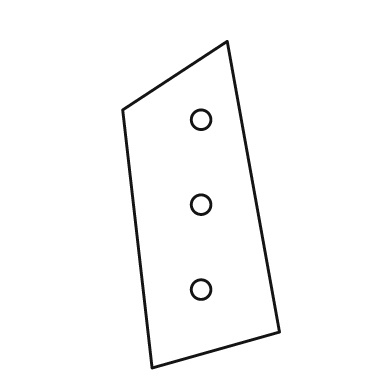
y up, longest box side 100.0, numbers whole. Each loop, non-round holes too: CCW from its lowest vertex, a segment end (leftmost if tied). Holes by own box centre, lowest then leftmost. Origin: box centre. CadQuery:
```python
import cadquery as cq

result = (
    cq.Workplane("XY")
    .moveTo(-15.0, -50.0)
    .lineTo(24.0, -39.0)
    .lineTo(8.0, 50.0)
    .lineTo(-24.0, 29.0)
    .close()
    .moveTo(0.0, -26.0)
    .circle(3.0)
    .moveTo(0.0, 0.0)
    .circle(3.0)
    .moveTo(0.0, 26.0)
    .circle(3.0)
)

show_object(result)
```